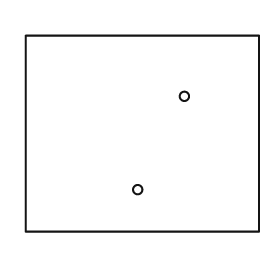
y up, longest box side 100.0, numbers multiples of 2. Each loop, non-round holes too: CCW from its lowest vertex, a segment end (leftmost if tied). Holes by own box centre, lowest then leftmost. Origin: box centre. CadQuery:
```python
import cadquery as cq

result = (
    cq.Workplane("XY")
    .moveTo(-50.0, -42.0)
    .lineTo(50.0, -42.0)
    .lineTo(50.0, 42.0)
    .lineTo(-50.0, 42.0)
    .close()
    .moveTo(-2.0, -24.0)
    .circle(2.0)
    .moveTo(18.0, 16.0)
    .circle(2.0)
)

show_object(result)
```